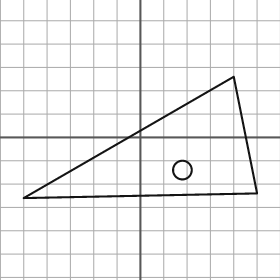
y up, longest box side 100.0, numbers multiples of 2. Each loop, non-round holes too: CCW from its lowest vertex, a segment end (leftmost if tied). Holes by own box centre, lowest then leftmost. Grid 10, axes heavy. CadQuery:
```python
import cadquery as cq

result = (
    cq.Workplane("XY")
    .moveTo(-50.0, -26.0)
    .lineTo(50.0, -24.0)
    .lineTo(40.0, 26.0)
    .close()
    .moveTo(18.0, -14.0)
    .circle(4.0)
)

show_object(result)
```